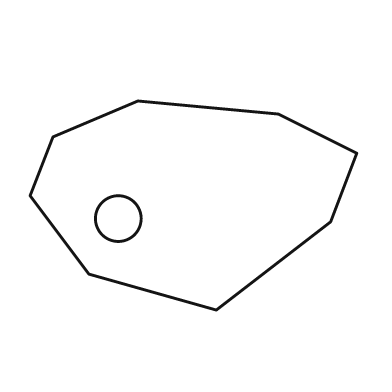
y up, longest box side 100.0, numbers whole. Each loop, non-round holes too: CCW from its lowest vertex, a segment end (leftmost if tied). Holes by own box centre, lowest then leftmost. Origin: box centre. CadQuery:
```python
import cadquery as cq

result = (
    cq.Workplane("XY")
    .moveTo(7.0, -32.0)
    .lineTo(42.0, -5.0)
    .lineTo(50.0, 16.0)
    .lineTo(26.0, 28.0)
    .lineTo(-17.0, 32.0)
    .lineTo(-43.0, 21.0)
    .lineTo(-50.0, 3.0)
    .lineTo(-32.0, -21.0)
    .close()
    .moveTo(-23.0, -4.0)
    .circle(7.0)
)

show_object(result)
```